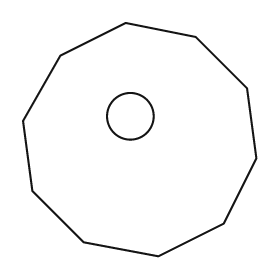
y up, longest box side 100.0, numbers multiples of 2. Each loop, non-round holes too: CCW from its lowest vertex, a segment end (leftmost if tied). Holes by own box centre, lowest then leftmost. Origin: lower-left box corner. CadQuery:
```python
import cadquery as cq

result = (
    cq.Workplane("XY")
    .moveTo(58.0, 0.0)
    .lineTo(86.0, 14.0)
    .lineTo(100.0, 42.0)
    .lineTo(96.0, 72.0)
    .lineTo(74.0, 94.0)
    .lineTo(44.0, 100.0)
    .lineTo(16.0, 86.0)
    .lineTo(0.0, 58.0)
    .lineTo(4.0, 28.0)
    .lineTo(26.0, 6.0)
    .close()
    .moveTo(46.0, 60.0)
    .circle(10.0)
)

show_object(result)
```